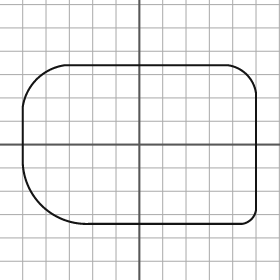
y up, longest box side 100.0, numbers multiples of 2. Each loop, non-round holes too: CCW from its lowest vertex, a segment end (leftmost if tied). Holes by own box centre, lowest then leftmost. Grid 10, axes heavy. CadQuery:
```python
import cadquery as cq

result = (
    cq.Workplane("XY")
    .moveTo(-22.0, -34.0)
    .lineTo(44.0, -34.0)
    .threePointArc((48.0, -32.0), (50.0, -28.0))
    .lineTo(50.0, 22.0)
    .threePointArc((46.0, 30.0), (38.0, 34.0))
    .lineTo(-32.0, 34.0)
    .threePointArc((-44.0, 28.0), (-50.0, 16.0))
    .lineTo(-50.0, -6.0)
    .threePointArc((-42.0, -26.0), (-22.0, -34.0))
    .close()
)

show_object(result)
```